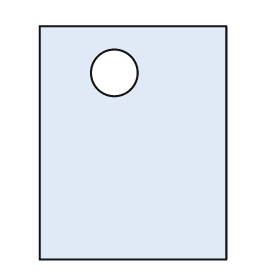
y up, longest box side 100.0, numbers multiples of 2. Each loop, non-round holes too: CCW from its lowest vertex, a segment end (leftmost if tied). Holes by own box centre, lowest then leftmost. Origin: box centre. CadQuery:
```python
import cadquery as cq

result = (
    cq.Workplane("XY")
    .moveTo(-40.0, -50.0)
    .lineTo(40.0, -50.0)
    .lineTo(40.0, 50.0)
    .lineTo(-40.0, 50.0)
    .close()
    .moveTo(-8.0, 30.0)
    .circle(10.0)
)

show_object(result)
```